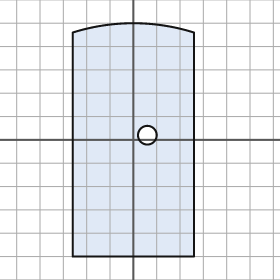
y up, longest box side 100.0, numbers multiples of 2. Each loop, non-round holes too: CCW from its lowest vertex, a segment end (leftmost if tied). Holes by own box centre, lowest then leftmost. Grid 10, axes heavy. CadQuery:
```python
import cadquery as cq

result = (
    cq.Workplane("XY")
    .moveTo(-26.0, -50.0)
    .lineTo(26.0, -50.0)
    .lineTo(26.0, 46.0)
    .threePointArc((0.0, 50.0), (-26.0, 46.0))
    .close()
    .moveTo(6.0, 2.0)
    .circle(4.0)
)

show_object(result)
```